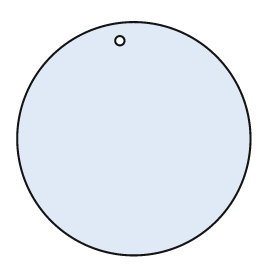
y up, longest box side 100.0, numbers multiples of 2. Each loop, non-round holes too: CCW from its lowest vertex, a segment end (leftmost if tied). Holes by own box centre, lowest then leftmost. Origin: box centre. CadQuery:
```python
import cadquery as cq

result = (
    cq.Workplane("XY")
    .moveTo(0.0, 0.0)
    .circle(50.0)
    .moveTo(-6.0, 42.0)
    .circle(2.0)
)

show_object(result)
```